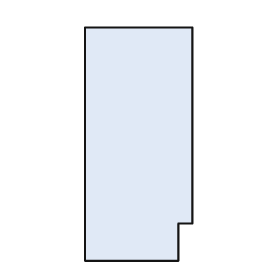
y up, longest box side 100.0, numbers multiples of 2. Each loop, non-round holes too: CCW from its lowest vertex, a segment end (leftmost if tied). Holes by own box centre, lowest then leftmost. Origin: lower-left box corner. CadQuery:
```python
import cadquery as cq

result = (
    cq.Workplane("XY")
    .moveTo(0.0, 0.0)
    .lineTo(40.0, 0.0)
    .lineTo(40.0, 16.0)
    .lineTo(46.0, 16.0)
    .lineTo(46.0, 100.0)
    .lineTo(0.0, 100.0)
    .close()
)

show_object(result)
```